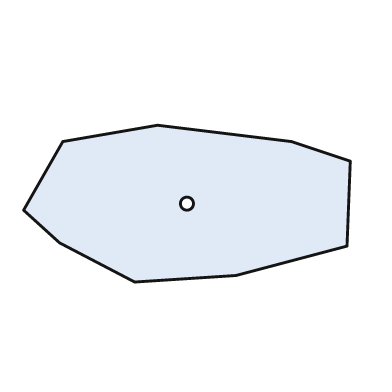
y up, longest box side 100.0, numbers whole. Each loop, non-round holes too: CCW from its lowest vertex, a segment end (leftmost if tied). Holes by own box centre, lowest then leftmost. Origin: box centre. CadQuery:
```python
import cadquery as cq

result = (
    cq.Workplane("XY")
    .moveTo(-16.0, -24.0)
    .lineTo(15.0, -22.0)
    .lineTo(49.0, -13.0)
    .lineTo(50.0, 13.0)
    .lineTo(32.0, 19.0)
    .lineTo(-9.0, 24.0)
    .lineTo(-38.0, 19.0)
    .lineTo(-50.0, -2.0)
    .lineTo(-39.0, -12.0)
    .close()
    .moveTo(0.0, 0.0)
    .circle(2.0)
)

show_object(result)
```